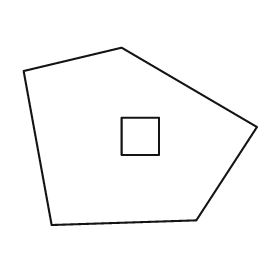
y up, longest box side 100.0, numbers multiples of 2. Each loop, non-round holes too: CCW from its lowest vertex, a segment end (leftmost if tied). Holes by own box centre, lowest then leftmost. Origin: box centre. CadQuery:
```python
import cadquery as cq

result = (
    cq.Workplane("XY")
    .moveTo(-38.0, -38.0)
    .lineTo(24.0, -36.0)
    .lineTo(50.0, 4.0)
    .lineTo(-8.0, 38.0)
    .lineTo(-50.0, 28.0)
    .close()
    .moveTo(-8.0, -8.0)
    .lineTo(8.0, -8.0)
    .lineTo(8.0, 8.0)
    .lineTo(-8.0, 8.0)
    .close()
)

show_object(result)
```